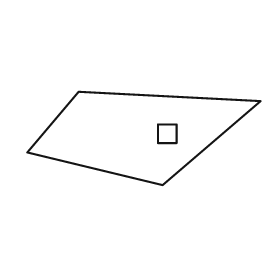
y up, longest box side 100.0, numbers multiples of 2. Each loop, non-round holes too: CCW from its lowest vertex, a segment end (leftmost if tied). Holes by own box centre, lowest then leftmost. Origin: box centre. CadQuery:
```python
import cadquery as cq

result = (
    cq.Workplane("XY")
    .moveTo(8.0, -20.0)
    .lineTo(50.0, 16.0)
    .lineTo(-28.0, 20.0)
    .lineTo(-50.0, -6.0)
    .close()
    .moveTo(6.0, -2.0)
    .lineTo(14.0, -2.0)
    .lineTo(14.0, 6.0)
    .lineTo(6.0, 6.0)
    .close()
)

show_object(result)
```